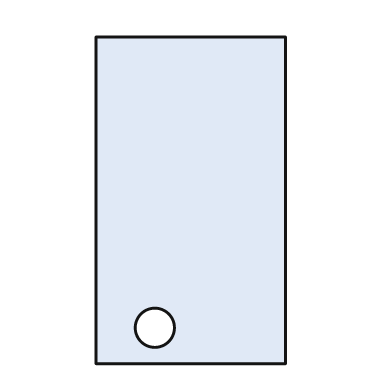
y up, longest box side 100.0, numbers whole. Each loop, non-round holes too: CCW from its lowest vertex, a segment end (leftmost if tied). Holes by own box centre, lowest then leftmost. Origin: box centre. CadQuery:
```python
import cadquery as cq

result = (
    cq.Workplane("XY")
    .moveTo(-29.0, -50.0)
    .lineTo(29.0, -50.0)
    .lineTo(29.0, 50.0)
    .lineTo(-29.0, 50.0)
    .close()
    .moveTo(-11.0, -39.0)
    .circle(6.0)
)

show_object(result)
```